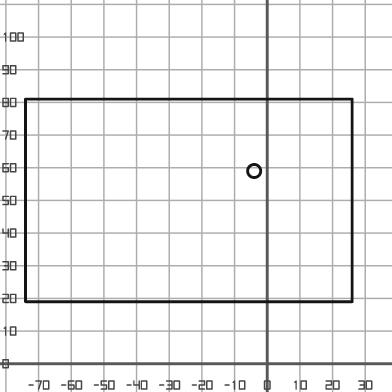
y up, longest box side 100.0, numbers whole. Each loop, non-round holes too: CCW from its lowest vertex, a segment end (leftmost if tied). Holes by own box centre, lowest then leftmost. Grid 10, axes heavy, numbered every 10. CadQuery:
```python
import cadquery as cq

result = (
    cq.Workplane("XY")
    .moveTo(-74.0, 19.0)
    .lineTo(26.0, 19.0)
    .lineTo(26.0, 81.0)
    .lineTo(-74.0, 81.0)
    .close()
    .moveTo(-4.0, 59.0)
    .circle(2.0)
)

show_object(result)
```